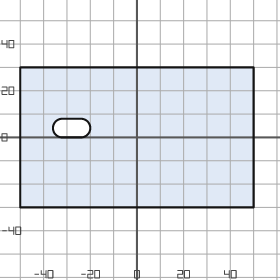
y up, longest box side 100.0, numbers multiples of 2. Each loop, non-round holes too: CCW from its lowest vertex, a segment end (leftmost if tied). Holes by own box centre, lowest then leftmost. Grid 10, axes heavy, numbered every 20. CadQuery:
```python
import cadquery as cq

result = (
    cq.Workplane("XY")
    .moveTo(-50.0, -30.0)
    .lineTo(50.0, -30.0)
    .lineTo(50.0, 30.0)
    .lineTo(-50.0, 30.0)
    .close()
    .moveTo(-32.0, 0.0)
    .lineTo(-24.0, 0.0)
    .threePointArc((-20.0, 4.0), (-24.0, 8.0))
    .lineTo(-32.0, 8.0)
    .threePointArc((-36.0, 4.0), (-32.0, 0.0))
    .close()
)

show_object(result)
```